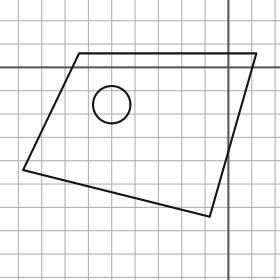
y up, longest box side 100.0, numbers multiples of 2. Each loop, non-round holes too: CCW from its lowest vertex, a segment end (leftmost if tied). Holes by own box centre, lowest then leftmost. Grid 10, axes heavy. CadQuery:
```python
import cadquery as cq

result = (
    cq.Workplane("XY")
    .moveTo(-8.0, -64.0)
    .lineTo(12.0, 6.0)
    .lineTo(-64.0, 6.0)
    .lineTo(-88.0, -44.0)
    .close()
    .moveTo(-50.0, -16.0)
    .circle(8.0)
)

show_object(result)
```